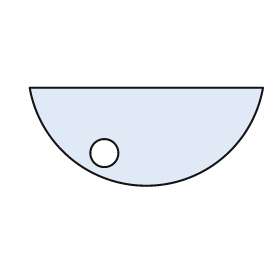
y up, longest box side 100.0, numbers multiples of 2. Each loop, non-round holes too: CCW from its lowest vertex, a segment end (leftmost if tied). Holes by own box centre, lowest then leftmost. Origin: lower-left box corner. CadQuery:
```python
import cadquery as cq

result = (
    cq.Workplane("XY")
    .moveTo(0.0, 42.0)
    .threePointArc((50.0, 0.0), (100.0, 42.0))
    .close()
    .moveTo(32.0, 14.0)
    .circle(6.0)
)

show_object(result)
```